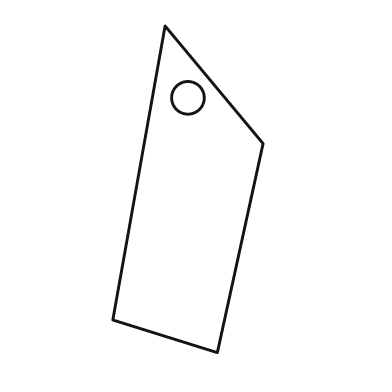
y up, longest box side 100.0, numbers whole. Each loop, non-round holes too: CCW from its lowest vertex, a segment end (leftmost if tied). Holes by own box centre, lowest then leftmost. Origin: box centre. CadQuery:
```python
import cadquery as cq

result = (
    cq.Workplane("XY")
    .moveTo(9.0, -50.0)
    .lineTo(23.0, 14.0)
    .lineTo(-7.0, 50.0)
    .lineTo(-23.0, -40.0)
    .close()
    .moveTo(0.0, 28.0)
    .circle(5.0)
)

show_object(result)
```